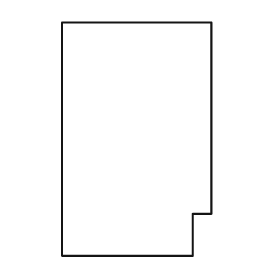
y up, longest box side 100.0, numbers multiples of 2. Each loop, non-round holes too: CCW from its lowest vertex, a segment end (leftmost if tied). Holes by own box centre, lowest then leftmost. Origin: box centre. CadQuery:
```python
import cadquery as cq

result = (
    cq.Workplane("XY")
    .moveTo(-32.0, -50.0)
    .lineTo(24.0, -50.0)
    .lineTo(24.0, -32.0)
    .lineTo(32.0, -32.0)
    .lineTo(32.0, 50.0)
    .lineTo(-32.0, 50.0)
    .close()
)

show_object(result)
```